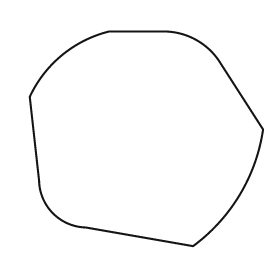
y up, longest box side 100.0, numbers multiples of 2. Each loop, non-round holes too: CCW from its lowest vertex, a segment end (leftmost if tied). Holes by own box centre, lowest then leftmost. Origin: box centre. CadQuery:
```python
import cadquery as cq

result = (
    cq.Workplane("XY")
    .moveTo(20.0, -46.0)
    .threePointArc((40.0, -24.0), (50.0, 4.0))
    .lineTo(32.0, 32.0)
    .threePointArc((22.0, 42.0), (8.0, 46.0))
    .lineTo(-16.0, 46.0)
    .threePointArc((-36.0, 36.0), (-50.0, 18.0))
    .lineTo(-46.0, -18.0)
    .threePointArc((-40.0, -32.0), (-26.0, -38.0))
    .close()
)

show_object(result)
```